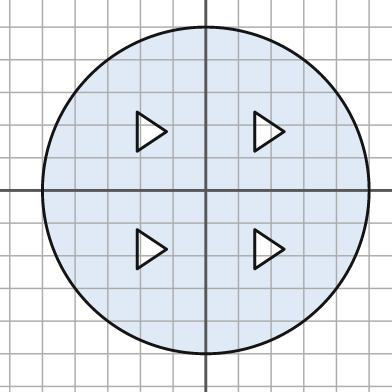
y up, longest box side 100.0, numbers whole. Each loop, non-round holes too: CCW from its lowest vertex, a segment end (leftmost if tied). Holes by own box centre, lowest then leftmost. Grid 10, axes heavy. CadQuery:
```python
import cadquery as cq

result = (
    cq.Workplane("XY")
    .moveTo(0.0, 0.0)
    .circle(50.0)
    .moveTo(-21.0, -24.0)
    .lineTo(-12.0, -18.0)
    .lineTo(-21.0, -12.0)
    .close()
    .moveTo(15.0, -24.0)
    .lineTo(24.0, -18.0)
    .lineTo(15.0, -12.0)
    .close()
    .moveTo(-21.0, 12.0)
    .lineTo(-12.0, 18.0)
    .lineTo(-21.0, 24.0)
    .close()
    .moveTo(15.0, 12.0)
    .lineTo(24.0, 18.0)
    .lineTo(15.0, 24.0)
    .close()
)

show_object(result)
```